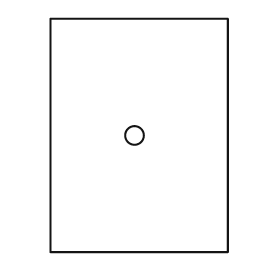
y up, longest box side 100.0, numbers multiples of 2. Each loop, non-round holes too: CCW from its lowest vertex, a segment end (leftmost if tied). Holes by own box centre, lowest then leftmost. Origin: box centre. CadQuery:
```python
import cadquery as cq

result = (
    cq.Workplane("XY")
    .moveTo(-38.0, -50.0)
    .lineTo(38.0, -50.0)
    .lineTo(38.0, 50.0)
    .lineTo(-38.0, 50.0)
    .close()
    .moveTo(-2.0, 0.0)
    .circle(4.0)
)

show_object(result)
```